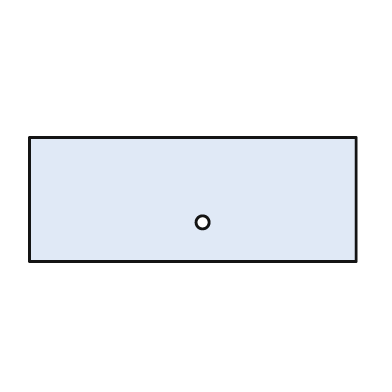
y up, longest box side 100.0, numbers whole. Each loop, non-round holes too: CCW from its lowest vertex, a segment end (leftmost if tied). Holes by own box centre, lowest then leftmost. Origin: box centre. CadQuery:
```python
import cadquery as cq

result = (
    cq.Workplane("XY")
    .moveTo(-50.0, -19.0)
    .lineTo(50.0, -19.0)
    .lineTo(50.0, 19.0)
    .lineTo(-50.0, 19.0)
    .close()
    .moveTo(3.0, -7.0)
    .circle(2.0)
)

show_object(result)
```